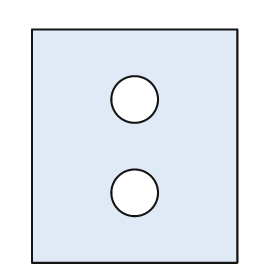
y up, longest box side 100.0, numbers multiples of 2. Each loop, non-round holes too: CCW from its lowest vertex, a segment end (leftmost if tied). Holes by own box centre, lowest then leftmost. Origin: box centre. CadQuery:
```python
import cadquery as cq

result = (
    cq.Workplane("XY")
    .moveTo(-44.0, -50.0)
    .lineTo(44.0, -50.0)
    .lineTo(44.0, 50.0)
    .lineTo(-44.0, 50.0)
    .close()
    .moveTo(0.0, -20.0)
    .circle(10.0)
    .moveTo(0.0, 20.0)
    .circle(10.0)
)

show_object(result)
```